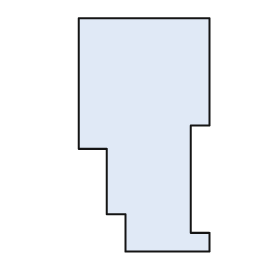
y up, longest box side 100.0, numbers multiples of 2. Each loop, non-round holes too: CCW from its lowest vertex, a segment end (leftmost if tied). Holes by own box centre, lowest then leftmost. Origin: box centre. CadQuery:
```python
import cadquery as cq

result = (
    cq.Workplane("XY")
    .moveTo(-8.0, -50.0)
    .lineTo(28.0, -50.0)
    .lineTo(28.0, -42.0)
    .lineTo(20.0, -42.0)
    .lineTo(20.0, 4.0)
    .lineTo(28.0, 4.0)
    .lineTo(28.0, 50.0)
    .lineTo(-28.0, 50.0)
    .lineTo(-28.0, -6.0)
    .lineTo(-16.0, -6.0)
    .lineTo(-16.0, -34.0)
    .lineTo(-8.0, -34.0)
    .close()
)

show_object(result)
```